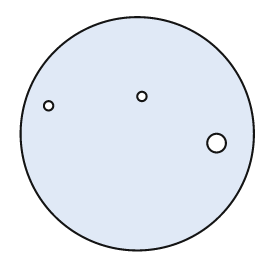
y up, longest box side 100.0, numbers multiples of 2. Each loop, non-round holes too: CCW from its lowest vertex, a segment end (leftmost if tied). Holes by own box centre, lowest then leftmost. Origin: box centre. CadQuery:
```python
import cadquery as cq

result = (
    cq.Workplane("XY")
    .moveTo(0.0, 0.0)
    .circle(50.0)
    .moveTo(34.0, -4.0)
    .circle(4.0)
    .moveTo(-38.0, 12.0)
    .circle(2.0)
    .moveTo(2.0, 16.0)
    .circle(2.0)
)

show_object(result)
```